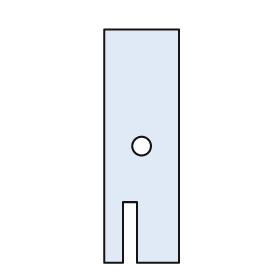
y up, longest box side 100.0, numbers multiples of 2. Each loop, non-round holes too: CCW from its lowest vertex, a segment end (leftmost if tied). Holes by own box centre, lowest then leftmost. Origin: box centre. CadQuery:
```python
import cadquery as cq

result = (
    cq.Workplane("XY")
    .moveTo(-16.0, -50.0)
    .lineTo(-8.0, -50.0)
    .lineTo(-8.0, -24.0)
    .lineTo(-2.0, -24.0)
    .lineTo(-2.0, -50.0)
    .lineTo(16.0, -50.0)
    .lineTo(16.0, 50.0)
    .lineTo(-16.0, 50.0)
    .close()
    .moveTo(0.0, 0.0)
    .circle(4.0)
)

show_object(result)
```